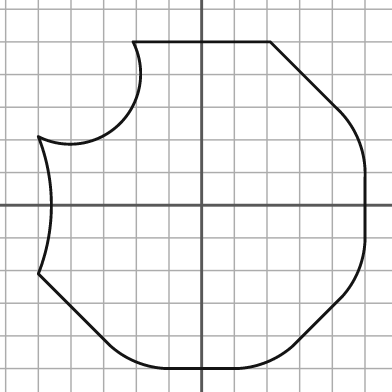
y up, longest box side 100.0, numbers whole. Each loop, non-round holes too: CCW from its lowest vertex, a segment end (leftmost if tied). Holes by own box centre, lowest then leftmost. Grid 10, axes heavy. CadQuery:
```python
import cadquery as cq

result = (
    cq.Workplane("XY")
    .moveTo(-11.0, -50.0)
    .lineTo(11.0, -50.0)
    .threePointArc((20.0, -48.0), (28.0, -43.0))
    .lineTo(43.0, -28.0)
    .threePointArc((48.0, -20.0), (50.0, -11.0))
    .lineTo(50.0, 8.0)
    .threePointArc((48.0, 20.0), (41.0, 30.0))
    .lineTo(21.0, 50.0)
    .lineTo(-21.0, 50.0)
    .threePointArc((-25.0, 25.0), (-50.0, 21.0))
    .threePointArc((-46.0, 0.0), (-50.0, -21.0))
    .lineTo(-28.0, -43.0)
    .threePointArc((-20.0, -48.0), (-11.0, -50.0))
    .close()
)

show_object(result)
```